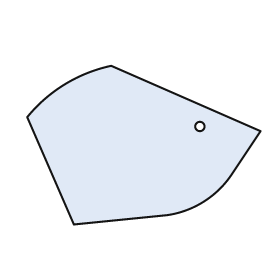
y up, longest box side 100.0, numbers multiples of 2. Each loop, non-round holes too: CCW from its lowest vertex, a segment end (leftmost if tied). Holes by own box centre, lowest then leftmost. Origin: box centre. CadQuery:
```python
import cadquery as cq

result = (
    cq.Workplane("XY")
    .moveTo(-30.0, -34.0)
    .lineTo(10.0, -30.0)
    .threePointArc((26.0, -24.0), (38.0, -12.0))
    .lineTo(50.0, 6.0)
    .lineTo(-14.0, 34.0)
    .threePointArc((-34.0, 26.0), (-50.0, 12.0))
    .close()
    .moveTo(24.0, 8.0)
    .circle(2.0)
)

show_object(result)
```